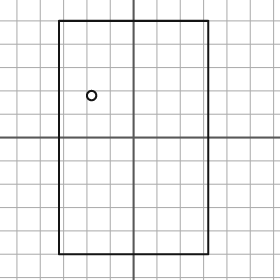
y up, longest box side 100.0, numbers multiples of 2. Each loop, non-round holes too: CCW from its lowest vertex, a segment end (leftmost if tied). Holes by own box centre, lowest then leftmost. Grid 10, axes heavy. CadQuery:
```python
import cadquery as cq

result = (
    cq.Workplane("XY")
    .moveTo(-32.0, -50.0)
    .lineTo(32.0, -50.0)
    .lineTo(32.0, 50.0)
    .lineTo(-32.0, 50.0)
    .close()
    .moveTo(-18.0, 18.0)
    .circle(2.0)
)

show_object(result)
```